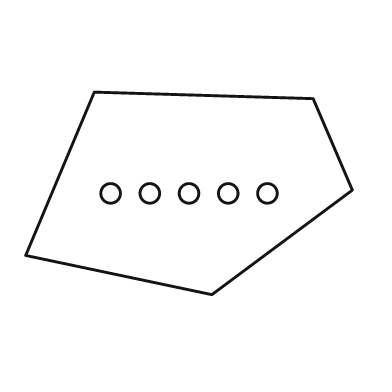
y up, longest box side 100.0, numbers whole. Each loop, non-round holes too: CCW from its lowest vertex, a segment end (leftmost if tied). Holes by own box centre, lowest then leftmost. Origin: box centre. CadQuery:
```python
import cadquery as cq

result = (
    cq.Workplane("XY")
    .moveTo(7.0, -31.0)
    .lineTo(50.0, 1.0)
    .lineTo(38.0, 29.0)
    .lineTo(-29.0, 31.0)
    .lineTo(-50.0, -19.0)
    .close()
    .moveTo(-24.0, 0.0)
    .circle(3.0)
    .moveTo(-12.0, 0.0)
    .circle(3.0)
    .moveTo(0.0, 0.0)
    .circle(3.0)
    .moveTo(12.0, 0.0)
    .circle(3.0)
    .moveTo(24.0, 0.0)
    .circle(3.0)
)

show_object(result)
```